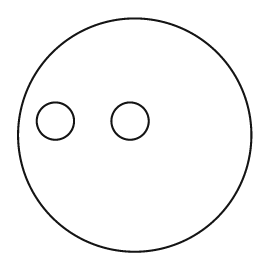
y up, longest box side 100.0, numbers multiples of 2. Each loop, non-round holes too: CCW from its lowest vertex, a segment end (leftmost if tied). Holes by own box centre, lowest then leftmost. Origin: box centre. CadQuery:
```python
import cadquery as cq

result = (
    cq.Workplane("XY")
    .moveTo(0.0, 0.0)
    .circle(50.0)
    .moveTo(-34.0, 6.0)
    .circle(8.0)
    .moveTo(-2.0, 6.0)
    .circle(8.0)
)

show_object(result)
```